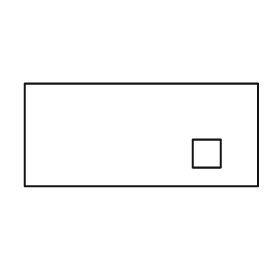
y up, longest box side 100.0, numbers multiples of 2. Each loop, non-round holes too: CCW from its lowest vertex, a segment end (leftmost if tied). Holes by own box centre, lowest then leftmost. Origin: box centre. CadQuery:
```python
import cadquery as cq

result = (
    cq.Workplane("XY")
    .moveTo(-50.0, -22.0)
    .lineTo(50.0, -22.0)
    .lineTo(50.0, 22.0)
    .lineTo(-50.0, 22.0)
    .close()
    .moveTo(22.0, -14.0)
    .lineTo(34.0, -14.0)
    .lineTo(34.0, -2.0)
    .lineTo(22.0, -2.0)
    .close()
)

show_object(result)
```